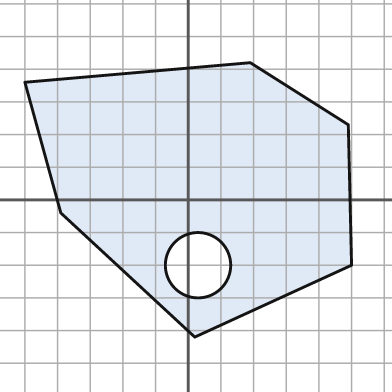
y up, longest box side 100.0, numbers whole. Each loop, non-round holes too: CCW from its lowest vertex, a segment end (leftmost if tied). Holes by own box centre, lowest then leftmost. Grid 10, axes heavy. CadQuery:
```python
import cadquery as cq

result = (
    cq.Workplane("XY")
    .moveTo(2.0, -42.0)
    .lineTo(50.0, -20.0)
    .lineTo(49.0, 23.0)
    .lineTo(19.0, 42.0)
    .lineTo(-50.0, 36.0)
    .lineTo(-39.0, -4.0)
    .close()
    .moveTo(3.0, -20.0)
    .circle(10.0)
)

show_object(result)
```